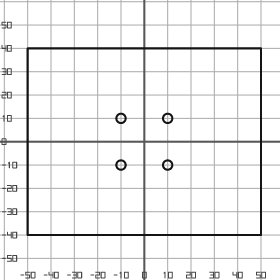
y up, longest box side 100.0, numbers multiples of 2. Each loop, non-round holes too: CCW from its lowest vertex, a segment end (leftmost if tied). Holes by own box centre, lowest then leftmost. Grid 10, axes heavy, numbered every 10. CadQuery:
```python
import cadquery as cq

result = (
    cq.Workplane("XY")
    .moveTo(-50.0, -40.0)
    .lineTo(50.0, -40.0)
    .lineTo(50.0, 40.0)
    .lineTo(-50.0, 40.0)
    .close()
    .moveTo(-10.0, -10.0)
    .circle(2.0)
    .moveTo(10.0, -10.0)
    .circle(2.0)
    .moveTo(-10.0, 10.0)
    .circle(2.0)
    .moveTo(10.0, 10.0)
    .circle(2.0)
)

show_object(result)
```